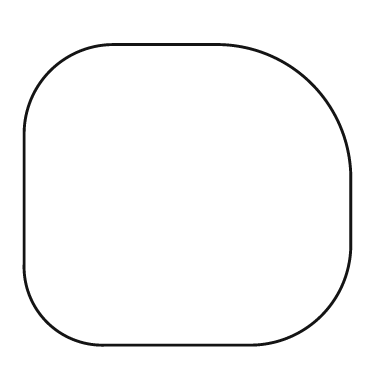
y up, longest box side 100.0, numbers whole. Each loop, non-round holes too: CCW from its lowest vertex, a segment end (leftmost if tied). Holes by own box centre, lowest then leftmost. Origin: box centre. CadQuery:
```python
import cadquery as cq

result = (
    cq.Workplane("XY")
    .moveTo(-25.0, -46.0)
    .lineTo(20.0, -46.0)
    .threePointArc((41.0, -37.0), (50.0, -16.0))
    .lineTo(50.0, 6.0)
    .threePointArc((38.0, 34.0), (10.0, 46.0))
    .lineTo(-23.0, 46.0)
    .threePointArc((-42.0, 38.0), (-50.0, 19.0))
    .lineTo(-50.0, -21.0)
    .threePointArc((-43.0, -39.0), (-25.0, -46.0))
    .close()
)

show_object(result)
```